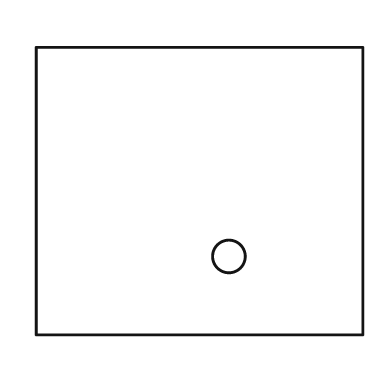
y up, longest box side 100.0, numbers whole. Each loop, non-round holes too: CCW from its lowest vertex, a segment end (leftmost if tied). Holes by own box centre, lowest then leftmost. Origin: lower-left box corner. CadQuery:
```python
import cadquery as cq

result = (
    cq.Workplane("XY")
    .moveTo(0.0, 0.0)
    .lineTo(100.0, 0.0)
    .lineTo(100.0, 88.0)
    .lineTo(0.0, 88.0)
    .close()
    .moveTo(59.0, 24.0)
    .circle(5.0)
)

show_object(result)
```